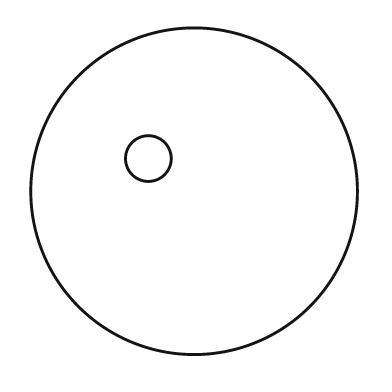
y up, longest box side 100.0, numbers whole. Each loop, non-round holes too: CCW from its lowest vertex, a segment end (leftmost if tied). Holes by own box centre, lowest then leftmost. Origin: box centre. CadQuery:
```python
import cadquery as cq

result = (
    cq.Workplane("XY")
    .moveTo(0.0, 0.0)
    .circle(50.0)
    .moveTo(-14.0, 10.0)
    .circle(7.0)
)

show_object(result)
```